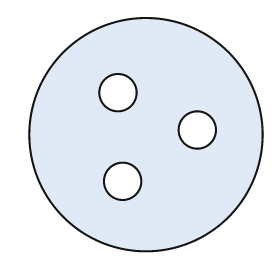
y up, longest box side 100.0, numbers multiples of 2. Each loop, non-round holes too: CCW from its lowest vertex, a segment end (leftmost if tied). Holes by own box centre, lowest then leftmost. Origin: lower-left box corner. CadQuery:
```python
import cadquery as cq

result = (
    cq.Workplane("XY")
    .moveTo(50.0, 50.0)
    .circle(50.0)
    .moveTo(40.0, 30.0)
    .circle(8.0)
    .moveTo(72.0, 52.0)
    .circle(8.0)
    .moveTo(38.0, 68.0)
    .circle(8.0)
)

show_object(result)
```